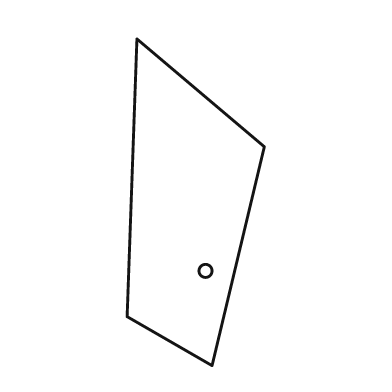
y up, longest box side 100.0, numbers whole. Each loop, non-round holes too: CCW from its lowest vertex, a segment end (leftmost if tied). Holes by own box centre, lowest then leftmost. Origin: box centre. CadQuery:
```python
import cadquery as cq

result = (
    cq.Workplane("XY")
    .moveTo(5.0, -50.0)
    .lineTo(21.0, 17.0)
    .lineTo(-18.0, 50.0)
    .lineTo(-21.0, -35.0)
    .close()
    .moveTo(3.0, -21.0)
    .circle(2.0)
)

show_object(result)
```